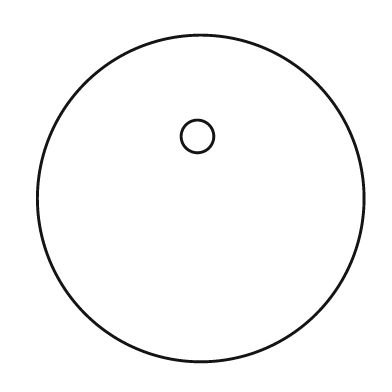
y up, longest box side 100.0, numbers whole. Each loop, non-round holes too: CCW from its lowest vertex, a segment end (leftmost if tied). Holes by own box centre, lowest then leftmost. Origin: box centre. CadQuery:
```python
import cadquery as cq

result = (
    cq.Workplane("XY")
    .moveTo(0.0, 0.0)
    .circle(50.0)
    .moveTo(-1.0, 19.0)
    .circle(5.0)
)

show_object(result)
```